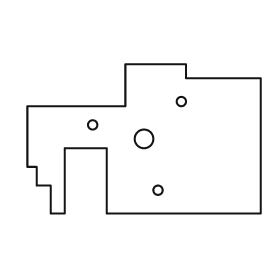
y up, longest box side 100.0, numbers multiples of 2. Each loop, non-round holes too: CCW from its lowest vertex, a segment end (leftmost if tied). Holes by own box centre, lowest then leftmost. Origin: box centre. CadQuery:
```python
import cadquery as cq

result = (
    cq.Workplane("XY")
    .moveTo(-40.0, -32.0)
    .lineTo(-34.0, -32.0)
    .lineTo(-34.0, -4.0)
    .lineTo(-16.0, -4.0)
    .lineTo(-16.0, -32.0)
    .lineTo(50.0, -32.0)
    .lineTo(50.0, 26.0)
    .lineTo(18.0, 26.0)
    .lineTo(18.0, 32.0)
    .lineTo(-8.0, 32.0)
    .lineTo(-8.0, 14.0)
    .lineTo(-50.0, 14.0)
    .lineTo(-50.0, -12.0)
    .lineTo(-46.0, -12.0)
    .lineTo(-46.0, -20.0)
    .lineTo(-40.0, -20.0)
    .close()
    .moveTo(6.0, -22.0)
    .circle(2.0)
    .moveTo(0.0, 0.0)
    .circle(4.0)
    .moveTo(-22.0, 6.0)
    .circle(2.0)
    .moveTo(16.0, 16.0)
    .circle(2.0)
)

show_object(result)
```